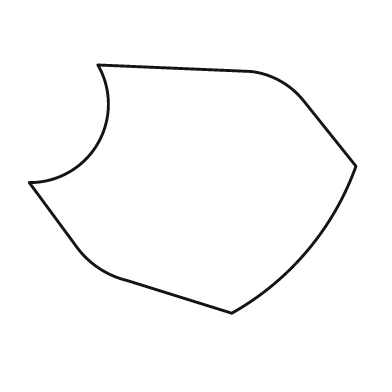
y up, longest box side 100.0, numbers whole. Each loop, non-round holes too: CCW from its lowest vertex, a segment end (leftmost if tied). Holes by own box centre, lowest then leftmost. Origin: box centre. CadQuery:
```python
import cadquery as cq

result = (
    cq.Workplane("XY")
    .moveTo(12.0, -38.0)
    .threePointArc((35.0, -19.0), (50.0, 7.0))
    .lineTo(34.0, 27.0)
    .threePointArc((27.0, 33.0), (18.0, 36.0))
    .lineTo(-29.0, 38.0)
    .threePointArc((-29.0, 14.0), (-50.0, 2.0))
    .lineTo(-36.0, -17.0)
    .threePointArc((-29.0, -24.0), (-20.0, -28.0))
    .close()
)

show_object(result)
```